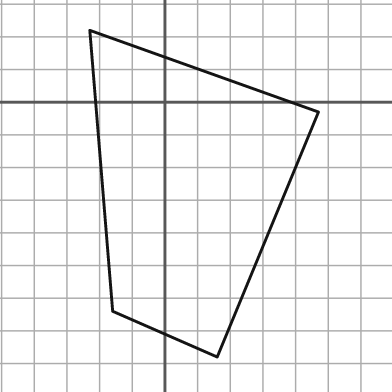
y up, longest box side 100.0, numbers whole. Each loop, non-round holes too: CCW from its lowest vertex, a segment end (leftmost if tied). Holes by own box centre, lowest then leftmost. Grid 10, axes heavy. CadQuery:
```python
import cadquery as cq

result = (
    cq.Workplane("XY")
    .moveTo(16.0, -78.0)
    .lineTo(47.0, -3.0)
    .lineTo(-23.0, 22.0)
    .lineTo(-16.0, -64.0)
    .close()
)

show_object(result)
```